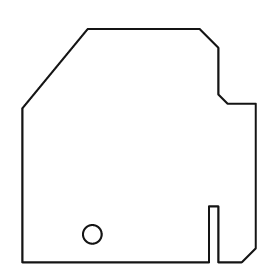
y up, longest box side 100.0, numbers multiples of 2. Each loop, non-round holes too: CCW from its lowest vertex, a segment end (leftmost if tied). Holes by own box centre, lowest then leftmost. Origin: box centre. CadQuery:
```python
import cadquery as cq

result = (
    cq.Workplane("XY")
    .moveTo(-50.0, -50.0)
    .lineTo(30.0, -50.0)
    .lineTo(30.0, -26.0)
    .lineTo(34.0, -26.0)
    .lineTo(34.0, -50.0)
    .lineTo(44.0, -50.0)
    .lineTo(50.0, -44.0)
    .lineTo(50.0, 18.0)
    .lineTo(38.0, 18.0)
    .lineTo(34.0, 22.0)
    .lineTo(34.0, 42.0)
    .lineTo(26.0, 50.0)
    .lineTo(-22.0, 50.0)
    .lineTo(-50.0, 16.0)
    .close()
    .moveTo(-20.0, -38.0)
    .circle(4.0)
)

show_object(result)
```